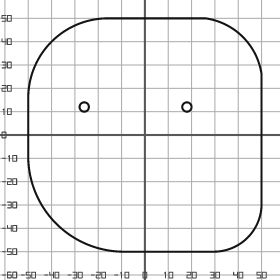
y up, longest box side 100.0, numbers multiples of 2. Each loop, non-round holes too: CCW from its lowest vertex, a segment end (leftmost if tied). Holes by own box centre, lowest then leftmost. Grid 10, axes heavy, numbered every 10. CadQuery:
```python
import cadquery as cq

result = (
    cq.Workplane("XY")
    .moveTo(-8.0, -50.0)
    .lineTo(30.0, -50.0)
    .threePointArc((44.0, -44.0), (50.0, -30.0))
    .lineTo(50.0, 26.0)
    .threePointArc((42.0, 42.0), (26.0, 50.0))
    .lineTo(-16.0, 50.0)
    .threePointArc((-40.0, 40.0), (-50.0, 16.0))
    .lineTo(-50.0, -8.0)
    .threePointArc((-38.0, -38.0), (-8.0, -50.0))
    .close()
    .moveTo(-26.0, 12.0)
    .circle(2.0)
    .moveTo(18.0, 12.0)
    .circle(2.0)
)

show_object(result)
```